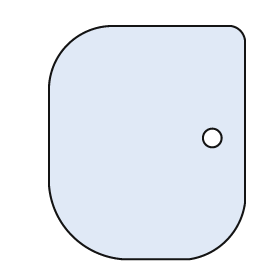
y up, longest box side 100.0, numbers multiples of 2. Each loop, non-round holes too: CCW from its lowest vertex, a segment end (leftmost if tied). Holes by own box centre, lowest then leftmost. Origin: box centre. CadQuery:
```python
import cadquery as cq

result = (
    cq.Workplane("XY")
    .moveTo(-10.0, -50.0)
    .lineTo(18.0, -50.0)
    .threePointArc((34.0, -42.0), (42.0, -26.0))
    .lineTo(42.0, 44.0)
    .threePointArc((40.0, 48.0), (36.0, 50.0))
    .lineTo(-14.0, 50.0)
    .threePointArc((-34.0, 42.0), (-42.0, 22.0))
    .lineTo(-42.0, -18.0)
    .threePointArc((-32.0, -40.0), (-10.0, -50.0))
    .close()
    .moveTo(28.0, 2.0)
    .circle(4.0)
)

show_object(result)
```